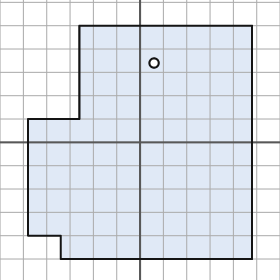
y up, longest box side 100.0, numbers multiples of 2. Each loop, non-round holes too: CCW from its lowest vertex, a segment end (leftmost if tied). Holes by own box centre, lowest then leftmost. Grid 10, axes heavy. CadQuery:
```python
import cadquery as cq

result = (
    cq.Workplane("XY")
    .moveTo(-34.0, -50.0)
    .lineTo(48.0, -50.0)
    .lineTo(48.0, 50.0)
    .lineTo(-26.0, 50.0)
    .lineTo(-26.0, 10.0)
    .lineTo(-48.0, 10.0)
    .lineTo(-48.0, -40.0)
    .lineTo(-34.0, -40.0)
    .close()
    .moveTo(6.0, 34.0)
    .circle(2.0)
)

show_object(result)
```